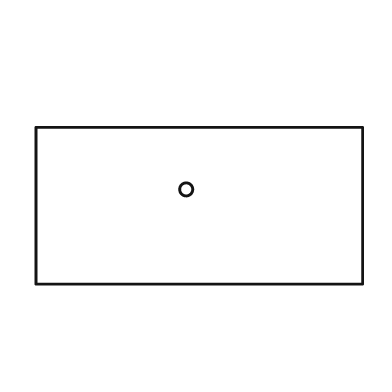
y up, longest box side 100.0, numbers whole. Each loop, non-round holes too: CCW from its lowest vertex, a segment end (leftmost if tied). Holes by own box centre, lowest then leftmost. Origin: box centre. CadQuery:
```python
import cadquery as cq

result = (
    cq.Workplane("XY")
    .moveTo(-50.0, -24.0)
    .lineTo(50.0, -24.0)
    .lineTo(50.0, 24.0)
    .lineTo(-50.0, 24.0)
    .close()
    .moveTo(-4.0, 5.0)
    .circle(2.0)
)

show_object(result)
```